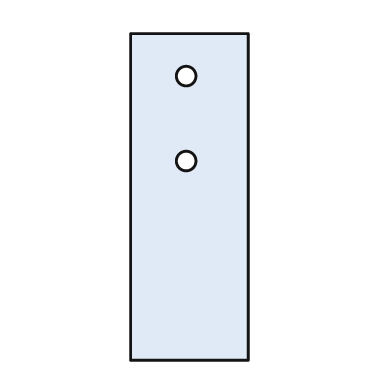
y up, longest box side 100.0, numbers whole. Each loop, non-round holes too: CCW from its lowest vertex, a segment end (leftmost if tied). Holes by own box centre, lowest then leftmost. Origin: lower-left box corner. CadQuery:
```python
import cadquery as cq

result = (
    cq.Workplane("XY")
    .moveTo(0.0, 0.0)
    .lineTo(36.0, 0.0)
    .lineTo(36.0, 100.0)
    .lineTo(0.0, 100.0)
    .close()
    .moveTo(17.0, 61.0)
    .circle(3.0)
    .moveTo(17.0, 87.0)
    .circle(3.0)
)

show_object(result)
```